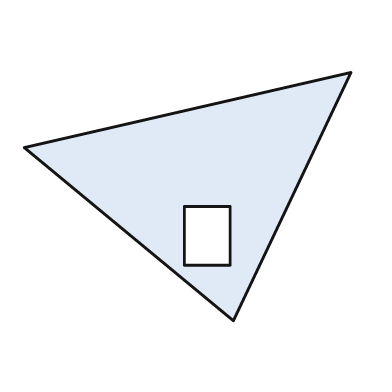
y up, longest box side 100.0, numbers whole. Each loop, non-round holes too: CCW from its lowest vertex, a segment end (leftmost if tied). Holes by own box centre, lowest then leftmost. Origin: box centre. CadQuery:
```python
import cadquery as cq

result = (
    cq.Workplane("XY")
    .moveTo(14.0, -38.0)
    .lineTo(50.0, 38.0)
    .lineTo(-50.0, 15.0)
    .close()
    .moveTo(-1.0, -21.0)
    .lineTo(13.0, -21.0)
    .lineTo(13.0, -3.0)
    .lineTo(-1.0, -3.0)
    .close()
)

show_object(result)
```